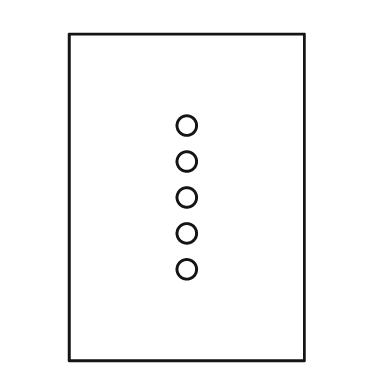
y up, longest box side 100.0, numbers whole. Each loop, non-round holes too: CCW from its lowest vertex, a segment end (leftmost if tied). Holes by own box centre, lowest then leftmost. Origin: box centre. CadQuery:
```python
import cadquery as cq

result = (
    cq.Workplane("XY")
    .moveTo(-36.0, -50.0)
    .lineTo(36.0, -50.0)
    .lineTo(36.0, 50.0)
    .lineTo(-36.0, 50.0)
    .close()
    .moveTo(0.0, -22.0)
    .circle(3.0)
    .moveTo(0.0, -11.0)
    .circle(3.0)
    .moveTo(0.0, 0.0)
    .circle(3.0)
    .moveTo(0.0, 11.0)
    .circle(3.0)
    .moveTo(0.0, 22.0)
    .circle(3.0)
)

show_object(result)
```